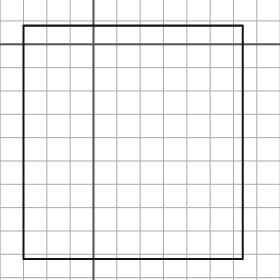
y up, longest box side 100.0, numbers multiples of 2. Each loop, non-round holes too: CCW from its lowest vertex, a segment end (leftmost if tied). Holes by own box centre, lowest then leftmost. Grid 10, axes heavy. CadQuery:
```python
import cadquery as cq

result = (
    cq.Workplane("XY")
    .moveTo(-30.0, -92.0)
    .lineTo(64.0, -92.0)
    .lineTo(64.0, 8.0)
    .lineTo(-30.0, 8.0)
    .close()
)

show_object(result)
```